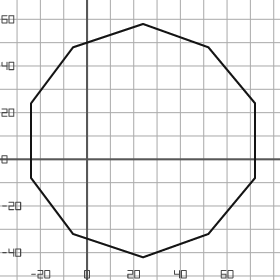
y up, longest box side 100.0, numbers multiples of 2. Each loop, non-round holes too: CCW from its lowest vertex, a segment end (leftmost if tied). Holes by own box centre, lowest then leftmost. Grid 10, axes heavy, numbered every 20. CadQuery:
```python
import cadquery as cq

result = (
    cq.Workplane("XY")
    .moveTo(24.0, -42.0)
    .lineTo(52.0, -32.0)
    .lineTo(72.0, -8.0)
    .lineTo(72.0, 24.0)
    .lineTo(52.0, 48.0)
    .lineTo(24.0, 58.0)
    .lineTo(-6.0, 48.0)
    .lineTo(-24.0, 24.0)
    .lineTo(-24.0, -8.0)
    .lineTo(-6.0, -32.0)
    .close()
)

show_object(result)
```